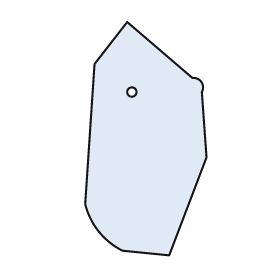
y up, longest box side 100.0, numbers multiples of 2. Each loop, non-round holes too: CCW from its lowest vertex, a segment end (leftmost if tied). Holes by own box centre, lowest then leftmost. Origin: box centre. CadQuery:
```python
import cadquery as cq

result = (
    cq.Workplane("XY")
    .moveTo(10.0, -50.0)
    .lineTo(26.0, -8.0)
    .lineTo(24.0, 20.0)
    .threePointArc((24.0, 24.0), (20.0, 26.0))
    .lineTo(-8.0, 50.0)
    .lineTo(-22.0, 32.0)
    .lineTo(-26.0, -28.0)
    .threePointArc((-20.0, -40.0), (-10.0, -48.0))
    .close()
    .moveTo(-6.0, 20.0)
    .circle(2.0)
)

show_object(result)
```